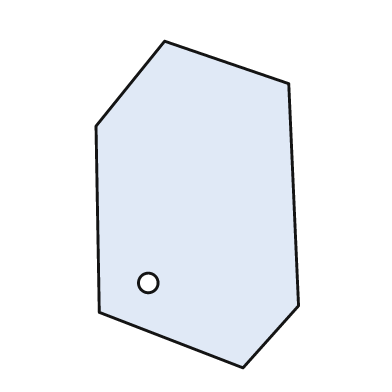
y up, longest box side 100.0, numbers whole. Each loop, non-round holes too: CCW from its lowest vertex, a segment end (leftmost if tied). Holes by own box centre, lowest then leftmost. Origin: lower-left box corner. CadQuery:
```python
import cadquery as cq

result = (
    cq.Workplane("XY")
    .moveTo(45.0, 0.0)
    .lineTo(62.0, 19.0)
    .lineTo(59.0, 87.0)
    .lineTo(21.0, 100.0)
    .lineTo(0.0, 74.0)
    .lineTo(1.0, 17.0)
    .close()
    .moveTo(16.0, 26.0)
    .circle(3.0)
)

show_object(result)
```